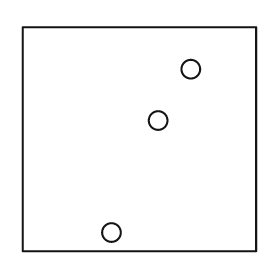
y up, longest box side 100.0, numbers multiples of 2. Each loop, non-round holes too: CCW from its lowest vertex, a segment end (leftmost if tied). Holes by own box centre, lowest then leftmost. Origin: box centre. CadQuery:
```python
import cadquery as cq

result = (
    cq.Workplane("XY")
    .moveTo(-50.0, -48.0)
    .lineTo(50.0, -48.0)
    .lineTo(50.0, 48.0)
    .lineTo(-50.0, 48.0)
    .close()
    .moveTo(-12.0, -40.0)
    .circle(4.0)
    .moveTo(8.0, 8.0)
    .circle(4.0)
    .moveTo(22.0, 30.0)
    .circle(4.0)
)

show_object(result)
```